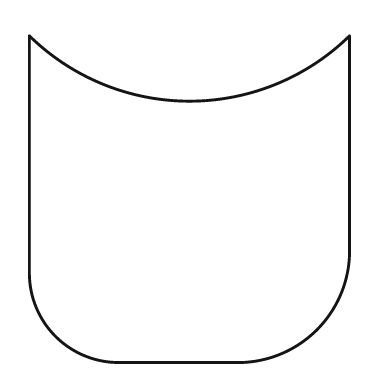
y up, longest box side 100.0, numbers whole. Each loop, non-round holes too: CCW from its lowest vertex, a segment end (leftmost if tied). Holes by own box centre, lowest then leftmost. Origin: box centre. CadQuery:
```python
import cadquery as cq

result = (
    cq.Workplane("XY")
    .moveTo(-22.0, -50.0)
    .lineTo(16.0, -50.0)
    .threePointArc((39.0, -40.0), (49.0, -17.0))
    .lineTo(49.0, 50.0)
    .threePointArc((0.0, 30.0), (-49.0, 50.0))
    .lineTo(-49.0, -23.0)
    .threePointArc((-41.0, -42.0), (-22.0, -50.0))
    .close()
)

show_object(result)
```